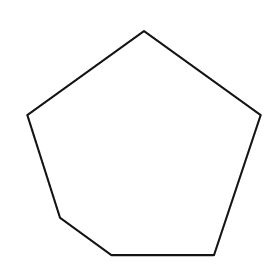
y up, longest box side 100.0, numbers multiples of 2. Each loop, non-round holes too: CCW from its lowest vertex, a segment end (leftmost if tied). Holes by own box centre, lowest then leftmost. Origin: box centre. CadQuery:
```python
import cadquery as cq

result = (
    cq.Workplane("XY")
    .moveTo(-14.0, -48.0)
    .lineTo(30.0, -48.0)
    .lineTo(50.0, 12.0)
    .lineTo(0.0, 48.0)
    .lineTo(-50.0, 12.0)
    .lineTo(-36.0, -32.0)
    .close()
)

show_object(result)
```